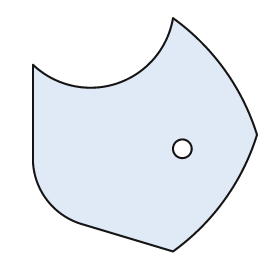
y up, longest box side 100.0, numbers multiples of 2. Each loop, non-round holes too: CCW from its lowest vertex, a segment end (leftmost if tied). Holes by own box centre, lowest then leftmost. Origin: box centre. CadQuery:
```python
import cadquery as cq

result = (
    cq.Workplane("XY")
    .moveTo(12.0, -50.0)
    .threePointArc((34.0, -28.0), (48.0, 0.0))
    .threePointArc((34.0, 28.0), (12.0, 50.0))
    .threePointArc((-12.0, 22.0), (-48.0, 30.0))
    .lineTo(-48.0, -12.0)
    .threePointArc((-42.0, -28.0), (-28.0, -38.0))
    .close()
    .moveTo(16.0, -6.0)
    .circle(4.0)
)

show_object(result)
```